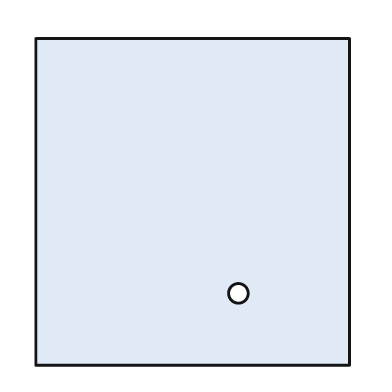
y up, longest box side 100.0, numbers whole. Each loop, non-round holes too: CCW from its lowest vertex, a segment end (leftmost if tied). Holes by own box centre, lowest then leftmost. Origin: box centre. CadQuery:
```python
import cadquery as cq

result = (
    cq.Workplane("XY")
    .moveTo(-48.0, -50.0)
    .lineTo(48.0, -50.0)
    .lineTo(48.0, 50.0)
    .lineTo(-48.0, 50.0)
    .close()
    .moveTo(14.0, -28.0)
    .circle(3.0)
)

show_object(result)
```